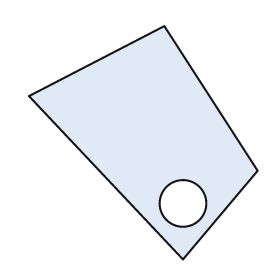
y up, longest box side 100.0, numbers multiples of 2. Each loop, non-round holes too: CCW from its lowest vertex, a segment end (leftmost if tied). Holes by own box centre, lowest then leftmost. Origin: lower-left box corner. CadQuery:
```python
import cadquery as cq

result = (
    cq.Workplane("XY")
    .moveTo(66.0, 0.0)
    .lineTo(98.0, 38.0)
    .lineTo(58.0, 100.0)
    .lineTo(0.0, 70.0)
    .close()
    .moveTo(66.0, 24.0)
    .circle(10.0)
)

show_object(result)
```